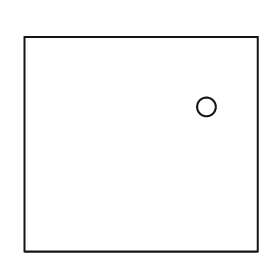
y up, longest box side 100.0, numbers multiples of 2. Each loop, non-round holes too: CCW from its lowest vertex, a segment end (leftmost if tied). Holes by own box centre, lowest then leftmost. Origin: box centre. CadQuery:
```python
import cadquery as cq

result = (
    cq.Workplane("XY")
    .moveTo(-50.0, -46.0)
    .lineTo(50.0, -46.0)
    .lineTo(50.0, 46.0)
    .lineTo(-50.0, 46.0)
    .close()
    .moveTo(28.0, 16.0)
    .circle(4.0)
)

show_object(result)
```